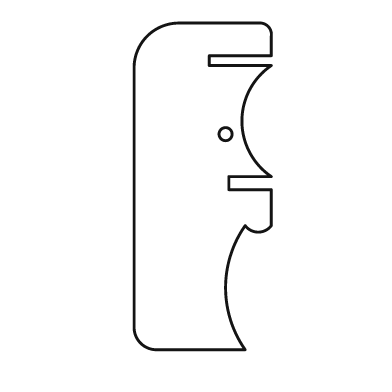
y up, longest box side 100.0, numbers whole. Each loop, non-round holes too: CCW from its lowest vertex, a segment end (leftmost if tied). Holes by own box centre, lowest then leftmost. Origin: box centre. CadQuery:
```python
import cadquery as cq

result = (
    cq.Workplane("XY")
    .moveTo(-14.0, -50.0)
    .lineTo(13.0, -50.0)
    .threePointArc((7.0, -31.0), (13.0, -12.0))
    .threePointArc((17.0, -14.0), (21.0, -12.0))
    .lineTo(21.0, -1.0)
    .lineTo(8.0, -1.0)
    .lineTo(8.0, 3.0)
    .lineTo(21.0, 3.0)
    .threePointArc((12.0, 20.0), (21.0, 37.0))
    .lineTo(2.0, 37.0)
    .lineTo(2.0, 40.0)
    .lineTo(21.0, 40.0)
    .lineTo(21.0, 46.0)
    .threePointArc((20.0, 49.0), (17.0, 50.0))
    .lineTo(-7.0, 50.0)
    .threePointArc((-17.0, 46.0), (-21.0, 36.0))
    .lineTo(-21.0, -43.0)
    .threePointArc((-19.0, -48.0), (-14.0, -50.0))
    .close()
    .moveTo(7.0, 16.0)
    .circle(2.0)
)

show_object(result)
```